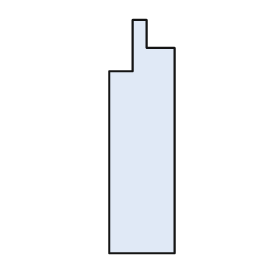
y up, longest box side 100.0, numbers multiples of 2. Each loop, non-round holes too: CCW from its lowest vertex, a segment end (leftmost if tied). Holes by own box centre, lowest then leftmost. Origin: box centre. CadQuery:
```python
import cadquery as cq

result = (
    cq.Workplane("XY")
    .moveTo(-14.0, -50.0)
    .lineTo(14.0, -50.0)
    .lineTo(14.0, 38.0)
    .lineTo(2.0, 38.0)
    .lineTo(2.0, 50.0)
    .lineTo(-4.0, 50.0)
    .lineTo(-4.0, 28.0)
    .lineTo(-14.0, 28.0)
    .close()
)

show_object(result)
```